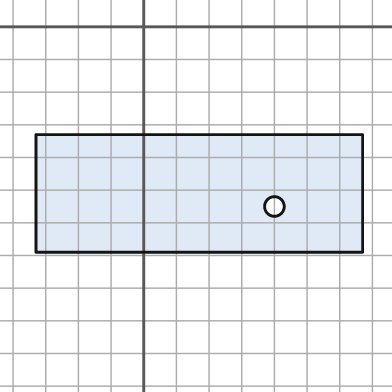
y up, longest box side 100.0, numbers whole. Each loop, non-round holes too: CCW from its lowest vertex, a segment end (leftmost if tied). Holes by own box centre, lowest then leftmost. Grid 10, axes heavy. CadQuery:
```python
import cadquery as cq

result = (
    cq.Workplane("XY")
    .moveTo(-33.0, -69.0)
    .lineTo(67.0, -69.0)
    .lineTo(67.0, -33.0)
    .lineTo(-33.0, -33.0)
    .close()
    .moveTo(40.0, -55.0)
    .circle(3.0)
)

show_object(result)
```